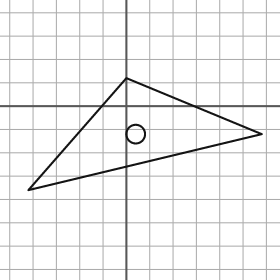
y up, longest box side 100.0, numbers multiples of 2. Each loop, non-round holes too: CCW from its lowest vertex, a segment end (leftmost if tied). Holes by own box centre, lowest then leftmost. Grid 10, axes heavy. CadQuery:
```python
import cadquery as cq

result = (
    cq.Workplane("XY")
    .moveTo(-42.0, -36.0)
    .lineTo(58.0, -12.0)
    .lineTo(0.0, 12.0)
    .close()
    .moveTo(4.0, -12.0)
    .circle(4.0)
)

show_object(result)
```